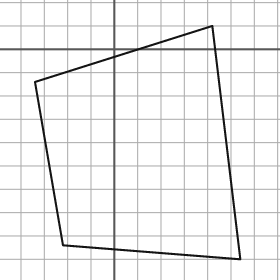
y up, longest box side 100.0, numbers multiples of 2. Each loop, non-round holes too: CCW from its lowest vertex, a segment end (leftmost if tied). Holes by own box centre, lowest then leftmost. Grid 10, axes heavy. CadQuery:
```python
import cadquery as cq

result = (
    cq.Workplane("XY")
    .moveTo(54.0, -90.0)
    .lineTo(42.0, 10.0)
    .lineTo(-34.0, -14.0)
    .lineTo(-22.0, -84.0)
    .close()
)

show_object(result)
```